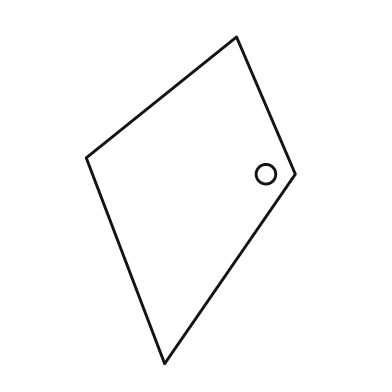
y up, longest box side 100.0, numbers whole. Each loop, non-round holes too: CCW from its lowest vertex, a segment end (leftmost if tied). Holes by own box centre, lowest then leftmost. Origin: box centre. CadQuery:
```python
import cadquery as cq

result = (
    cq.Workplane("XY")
    .moveTo(-8.0, -50.0)
    .lineTo(32.0, 8.0)
    .lineTo(14.0, 50.0)
    .lineTo(-32.0, 13.0)
    .close()
    .moveTo(23.0, 8.0)
    .circle(3.0)
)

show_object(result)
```